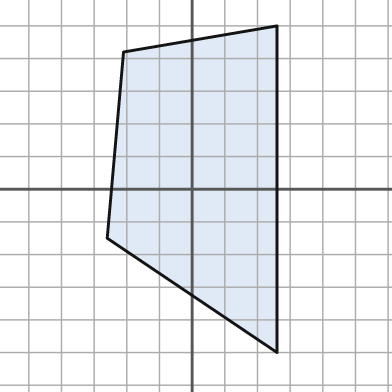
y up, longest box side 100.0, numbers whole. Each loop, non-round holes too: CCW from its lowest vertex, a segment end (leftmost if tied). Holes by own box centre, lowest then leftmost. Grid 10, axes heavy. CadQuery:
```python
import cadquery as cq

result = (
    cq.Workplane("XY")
    .moveTo(26.0, -50.0)
    .lineTo(26.0, 50.0)
    .lineTo(-21.0, 42.0)
    .lineTo(-26.0, -15.0)
    .close()
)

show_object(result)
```